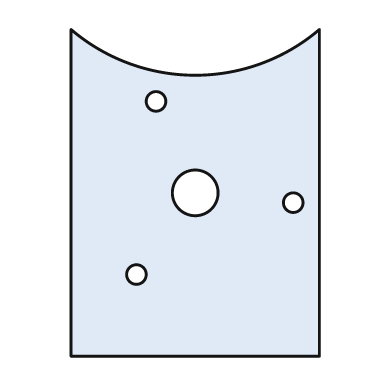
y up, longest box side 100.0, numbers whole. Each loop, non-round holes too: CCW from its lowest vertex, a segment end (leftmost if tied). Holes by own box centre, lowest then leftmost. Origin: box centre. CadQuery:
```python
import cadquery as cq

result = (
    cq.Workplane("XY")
    .moveTo(-38.0, -50.0)
    .lineTo(38.0, -50.0)
    .lineTo(38.0, 50.0)
    .threePointArc((0.0, 36.0), (-38.0, 50.0))
    .close()
    .moveTo(-18.0, -25.0)
    .circle(3.0)
    .moveTo(30.0, -3.0)
    .circle(3.0)
    .moveTo(0.0, 0.0)
    .circle(7.0)
    .moveTo(-12.0, 28.0)
    .circle(3.0)
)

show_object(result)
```